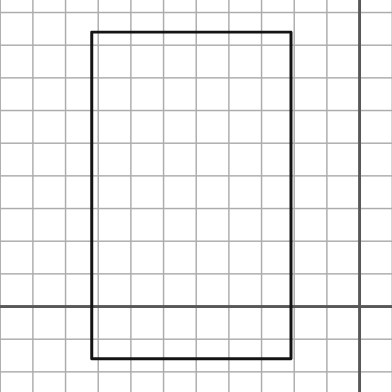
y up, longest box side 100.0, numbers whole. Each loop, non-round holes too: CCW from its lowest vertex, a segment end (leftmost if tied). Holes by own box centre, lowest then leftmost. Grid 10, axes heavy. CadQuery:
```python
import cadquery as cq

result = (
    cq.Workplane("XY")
    .moveTo(-82.0, -16.0)
    .lineTo(-21.0, -16.0)
    .lineTo(-21.0, 84.0)
    .lineTo(-82.0, 84.0)
    .close()
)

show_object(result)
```